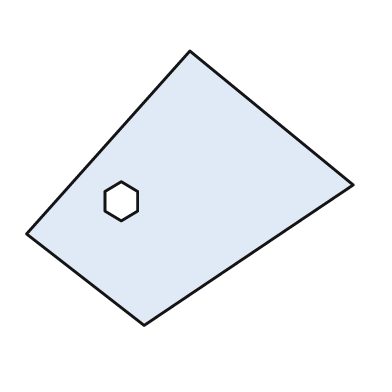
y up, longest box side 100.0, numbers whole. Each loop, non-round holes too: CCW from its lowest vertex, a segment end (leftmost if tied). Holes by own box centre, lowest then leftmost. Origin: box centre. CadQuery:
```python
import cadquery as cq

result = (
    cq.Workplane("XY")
    .moveTo(-14.0, -42.0)
    .lineTo(50.0, 1.0)
    .lineTo(0.0, 42.0)
    .lineTo(-50.0, -14.0)
    .close()
    .moveTo(-21.0, -10.0)
    .lineTo(-16.0, -7.0)
    .lineTo(-16.0, -1.0)
    .lineTo(-21.0, 2.0)
    .lineTo(-26.0, -1.0)
    .lineTo(-26.0, -7.0)
    .close()
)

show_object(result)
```